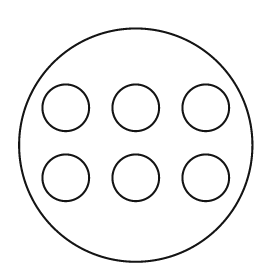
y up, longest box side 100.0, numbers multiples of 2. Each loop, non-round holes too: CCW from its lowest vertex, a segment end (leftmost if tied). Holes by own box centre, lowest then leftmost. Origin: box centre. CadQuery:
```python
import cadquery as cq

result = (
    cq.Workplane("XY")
    .moveTo(0.0, 0.0)
    .circle(50.0)
    .moveTo(-30.0, -14.0)
    .circle(10.0)
    .moveTo(0.0, -14.0)
    .circle(10.0)
    .moveTo(30.0, -14.0)
    .circle(10.0)
    .moveTo(-30.0, 16.0)
    .circle(10.0)
    .moveTo(0.0, 16.0)
    .circle(10.0)
    .moveTo(30.0, 16.0)
    .circle(10.0)
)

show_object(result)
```